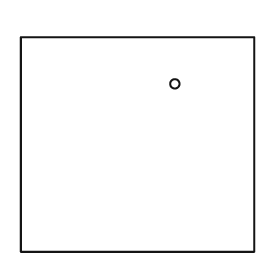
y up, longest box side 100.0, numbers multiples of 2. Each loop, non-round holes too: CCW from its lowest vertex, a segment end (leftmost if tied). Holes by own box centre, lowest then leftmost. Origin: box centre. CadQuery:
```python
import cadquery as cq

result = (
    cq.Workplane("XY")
    .moveTo(-50.0, -46.0)
    .lineTo(50.0, -46.0)
    .lineTo(50.0, 46.0)
    .lineTo(-50.0, 46.0)
    .close()
    .moveTo(16.0, 26.0)
    .circle(2.0)
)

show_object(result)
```